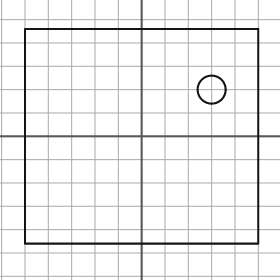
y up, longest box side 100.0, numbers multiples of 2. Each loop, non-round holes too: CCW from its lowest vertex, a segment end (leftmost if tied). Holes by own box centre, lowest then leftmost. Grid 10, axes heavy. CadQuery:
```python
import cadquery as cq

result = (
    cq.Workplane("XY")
    .moveTo(-50.0, -46.0)
    .lineTo(50.0, -46.0)
    .lineTo(50.0, 46.0)
    .lineTo(-50.0, 46.0)
    .close()
    .moveTo(30.0, 20.0)
    .circle(6.0)
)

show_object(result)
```